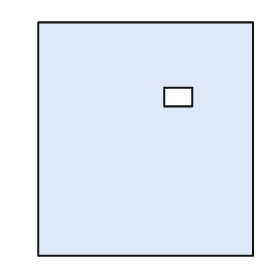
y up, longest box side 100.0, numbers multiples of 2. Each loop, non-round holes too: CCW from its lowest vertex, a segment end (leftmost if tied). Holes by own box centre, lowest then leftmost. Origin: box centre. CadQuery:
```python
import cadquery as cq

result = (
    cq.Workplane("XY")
    .moveTo(-46.0, -50.0)
    .lineTo(46.0, -50.0)
    .lineTo(46.0, 50.0)
    .lineTo(-46.0, 50.0)
    .close()
    .moveTo(8.0, 14.0)
    .lineTo(20.0, 14.0)
    .lineTo(20.0, 22.0)
    .lineTo(8.0, 22.0)
    .close()
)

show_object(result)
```